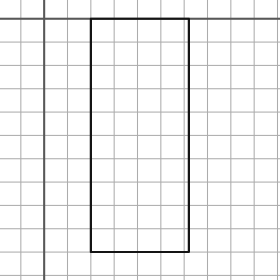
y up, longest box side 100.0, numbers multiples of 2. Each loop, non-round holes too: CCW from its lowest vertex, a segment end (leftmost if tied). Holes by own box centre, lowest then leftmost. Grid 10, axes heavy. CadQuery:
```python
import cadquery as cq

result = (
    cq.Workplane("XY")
    .moveTo(20.0, -100.0)
    .lineTo(62.0, -100.0)
    .lineTo(62.0, 0.0)
    .lineTo(20.0, 0.0)
    .close()
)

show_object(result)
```